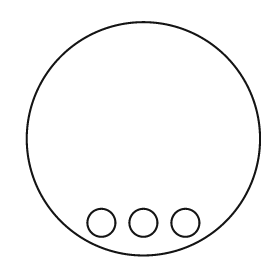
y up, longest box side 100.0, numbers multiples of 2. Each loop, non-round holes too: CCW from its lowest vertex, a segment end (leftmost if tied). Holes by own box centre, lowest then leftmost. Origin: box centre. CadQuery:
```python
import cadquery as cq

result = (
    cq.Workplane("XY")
    .moveTo(0.0, 0.0)
    .circle(50.0)
    .moveTo(-18.0, -36.0)
    .circle(6.0)
    .moveTo(0.0, -36.0)
    .circle(6.0)
    .moveTo(18.0, -36.0)
    .circle(6.0)
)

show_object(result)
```